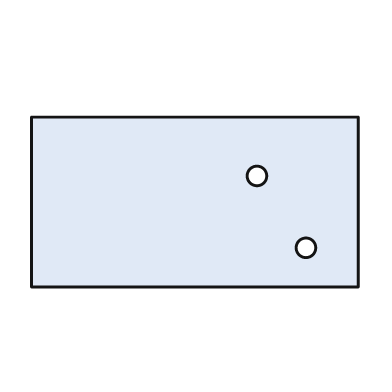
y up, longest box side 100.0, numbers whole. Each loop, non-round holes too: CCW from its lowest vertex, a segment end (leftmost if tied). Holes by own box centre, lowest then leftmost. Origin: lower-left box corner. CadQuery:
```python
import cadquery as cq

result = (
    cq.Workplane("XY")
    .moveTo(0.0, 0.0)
    .lineTo(100.0, 0.0)
    .lineTo(100.0, 52.0)
    .lineTo(0.0, 52.0)
    .close()
    .moveTo(84.0, 12.0)
    .circle(3.0)
    .moveTo(69.0, 34.0)
    .circle(3.0)
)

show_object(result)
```